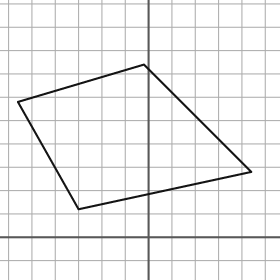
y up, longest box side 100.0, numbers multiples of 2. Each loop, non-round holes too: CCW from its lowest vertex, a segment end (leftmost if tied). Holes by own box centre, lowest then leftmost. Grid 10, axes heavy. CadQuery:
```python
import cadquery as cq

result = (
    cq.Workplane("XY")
    .moveTo(-30.0, 12.0)
    .lineTo(44.0, 28.0)
    .lineTo(-2.0, 74.0)
    .lineTo(-56.0, 58.0)
    .close()
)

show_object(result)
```